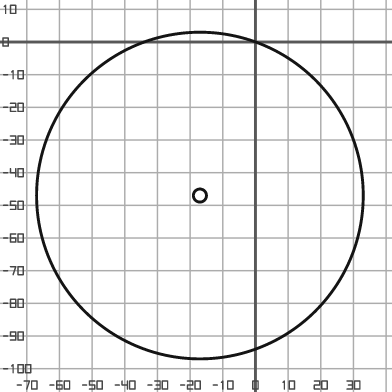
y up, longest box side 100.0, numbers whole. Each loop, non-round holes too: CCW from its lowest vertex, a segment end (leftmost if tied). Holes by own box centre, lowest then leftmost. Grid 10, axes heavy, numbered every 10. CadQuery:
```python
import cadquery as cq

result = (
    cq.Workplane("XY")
    .moveTo(-17.0, -47.0)
    .circle(50.0)
    .moveTo(-17.0, -47.0)
    .circle(2.0)
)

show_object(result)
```